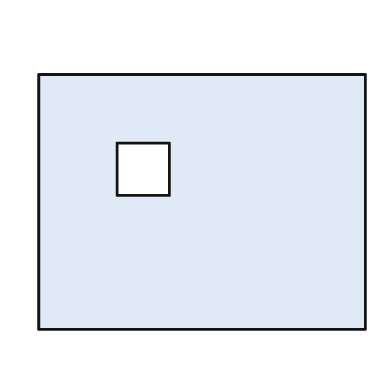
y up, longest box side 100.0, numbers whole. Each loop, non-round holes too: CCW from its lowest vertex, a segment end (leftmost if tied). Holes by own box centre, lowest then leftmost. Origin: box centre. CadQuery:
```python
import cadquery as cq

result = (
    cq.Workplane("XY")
    .moveTo(-50.0, -39.0)
    .lineTo(50.0, -39.0)
    .lineTo(50.0, 39.0)
    .lineTo(-50.0, 39.0)
    .close()
    .moveTo(-26.0, 2.0)
    .lineTo(-10.0, 2.0)
    .lineTo(-10.0, 18.0)
    .lineTo(-26.0, 18.0)
    .close()
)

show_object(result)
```